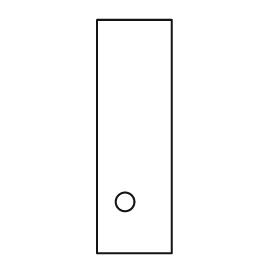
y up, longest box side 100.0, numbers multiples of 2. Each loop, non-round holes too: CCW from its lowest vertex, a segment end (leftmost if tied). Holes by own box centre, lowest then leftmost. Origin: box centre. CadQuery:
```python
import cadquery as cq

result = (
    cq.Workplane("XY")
    .moveTo(-16.0, -50.0)
    .lineTo(16.0, -50.0)
    .lineTo(16.0, 50.0)
    .lineTo(-16.0, 50.0)
    .close()
    .moveTo(-4.0, -28.0)
    .circle(4.0)
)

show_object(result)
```